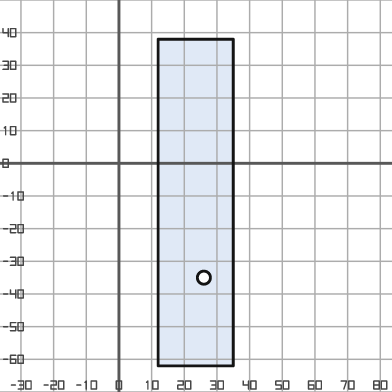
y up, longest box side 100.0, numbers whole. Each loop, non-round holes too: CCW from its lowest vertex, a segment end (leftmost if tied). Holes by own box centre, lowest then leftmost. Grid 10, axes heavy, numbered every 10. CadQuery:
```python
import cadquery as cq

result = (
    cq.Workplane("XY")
    .moveTo(12.0, -62.0)
    .lineTo(35.0, -62.0)
    .lineTo(35.0, 38.0)
    .lineTo(12.0, 38.0)
    .close()
    .moveTo(26.0, -35.0)
    .circle(2.0)
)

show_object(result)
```